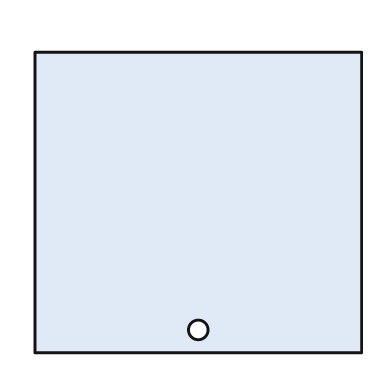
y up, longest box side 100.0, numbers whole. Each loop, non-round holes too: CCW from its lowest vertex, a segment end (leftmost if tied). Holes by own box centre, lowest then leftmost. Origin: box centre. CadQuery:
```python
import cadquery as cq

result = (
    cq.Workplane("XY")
    .moveTo(-50.0, -46.0)
    .lineTo(50.0, -46.0)
    .lineTo(50.0, 46.0)
    .lineTo(-50.0, 46.0)
    .close()
    .moveTo(0.0, -39.0)
    .circle(3.0)
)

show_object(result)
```